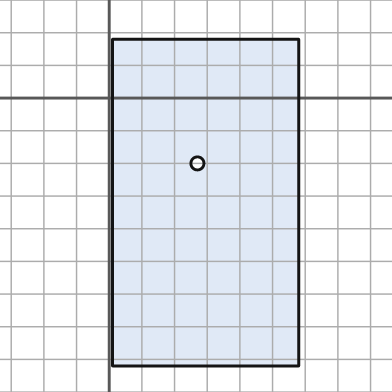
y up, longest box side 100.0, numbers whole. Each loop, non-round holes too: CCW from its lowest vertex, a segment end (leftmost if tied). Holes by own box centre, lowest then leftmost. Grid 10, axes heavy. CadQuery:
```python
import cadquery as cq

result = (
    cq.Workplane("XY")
    .moveTo(1.0, -82.0)
    .lineTo(58.0, -82.0)
    .lineTo(58.0, 18.0)
    .lineTo(1.0, 18.0)
    .close()
    .moveTo(27.0, -20.0)
    .circle(2.0)
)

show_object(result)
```